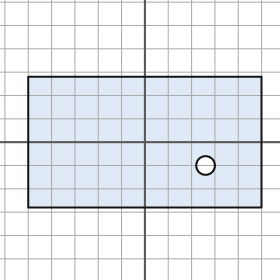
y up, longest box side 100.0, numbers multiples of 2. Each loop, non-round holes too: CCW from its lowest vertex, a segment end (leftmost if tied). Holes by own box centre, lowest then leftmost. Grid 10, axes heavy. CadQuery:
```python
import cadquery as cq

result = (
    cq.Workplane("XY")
    .moveTo(-50.0, -28.0)
    .lineTo(50.0, -28.0)
    .lineTo(50.0, 28.0)
    .lineTo(-50.0, 28.0)
    .close()
    .moveTo(26.0, -10.0)
    .circle(4.0)
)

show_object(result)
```